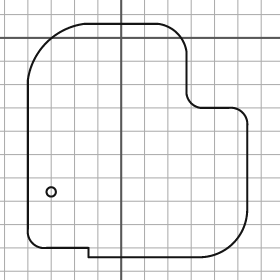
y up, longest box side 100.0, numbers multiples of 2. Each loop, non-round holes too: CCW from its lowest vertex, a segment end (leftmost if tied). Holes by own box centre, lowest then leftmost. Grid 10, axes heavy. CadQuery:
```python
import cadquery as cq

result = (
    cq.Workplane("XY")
    .moveTo(-14.0, -94.0)
    .lineTo(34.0, -94.0)
    .threePointArc((48.0, -88.0), (54.0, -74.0))
    .lineTo(54.0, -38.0)
    .threePointArc((52.0, -32.0), (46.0, -30.0))
    .lineTo(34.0, -30.0)
    .threePointArc((30.0, -28.0), (28.0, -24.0))
    .lineTo(28.0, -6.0)
    .threePointArc((24.0, 2.0), (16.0, 6.0))
    .lineTo(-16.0, 6.0)
    .threePointArc((-32.0, -2.0), (-40.0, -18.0))
    .lineTo(-40.0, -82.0)
    .threePointArc((-38.0, -88.0), (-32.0, -90.0))
    .lineTo(-14.0, -90.0)
    .close()
    .moveTo(-30.0, -66.0)
    .circle(2.0)
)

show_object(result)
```